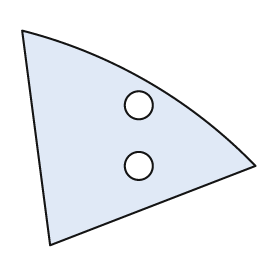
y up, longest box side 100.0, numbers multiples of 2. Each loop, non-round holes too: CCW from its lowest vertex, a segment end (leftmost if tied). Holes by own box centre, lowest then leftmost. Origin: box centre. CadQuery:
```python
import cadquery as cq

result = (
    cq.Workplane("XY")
    .moveTo(-38.0, -46.0)
    .lineTo(50.0, -12.0)
    .threePointArc((4.0, 24.0), (-50.0, 46.0))
    .close()
    .moveTo(0.0, -12.0)
    .circle(6.0)
    .moveTo(0.0, 14.0)
    .circle(6.0)
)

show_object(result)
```